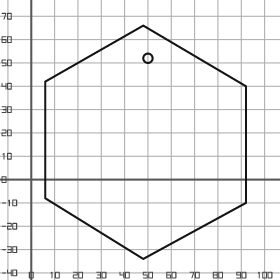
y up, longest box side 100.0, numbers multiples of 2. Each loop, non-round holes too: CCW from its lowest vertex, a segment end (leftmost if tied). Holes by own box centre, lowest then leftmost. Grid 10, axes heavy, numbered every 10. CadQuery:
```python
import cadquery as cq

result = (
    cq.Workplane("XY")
    .moveTo(48.0, -34.0)
    .lineTo(92.0, -10.0)
    .lineTo(92.0, 40.0)
    .lineTo(48.0, 66.0)
    .lineTo(6.0, 42.0)
    .lineTo(6.0, -8.0)
    .close()
    .moveTo(50.0, 52.0)
    .circle(2.0)
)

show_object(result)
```